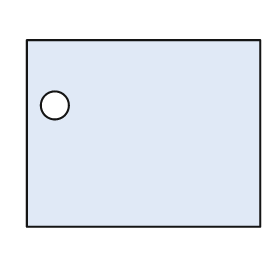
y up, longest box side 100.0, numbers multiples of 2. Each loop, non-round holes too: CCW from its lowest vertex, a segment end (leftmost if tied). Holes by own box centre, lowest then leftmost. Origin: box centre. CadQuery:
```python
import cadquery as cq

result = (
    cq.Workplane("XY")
    .moveTo(-50.0, -40.0)
    .lineTo(50.0, -40.0)
    .lineTo(50.0, 40.0)
    .lineTo(-50.0, 40.0)
    .close()
    .moveTo(-38.0, 12.0)
    .circle(6.0)
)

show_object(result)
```